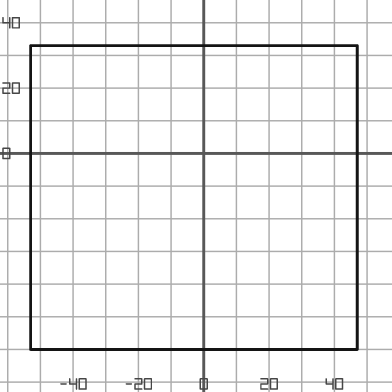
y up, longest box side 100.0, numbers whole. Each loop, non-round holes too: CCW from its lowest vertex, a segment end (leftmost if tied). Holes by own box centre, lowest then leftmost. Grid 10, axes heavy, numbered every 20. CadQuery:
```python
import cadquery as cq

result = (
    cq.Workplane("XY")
    .moveTo(-53.0, -60.0)
    .lineTo(47.0, -60.0)
    .lineTo(47.0, 33.0)
    .lineTo(-53.0, 33.0)
    .close()
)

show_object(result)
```